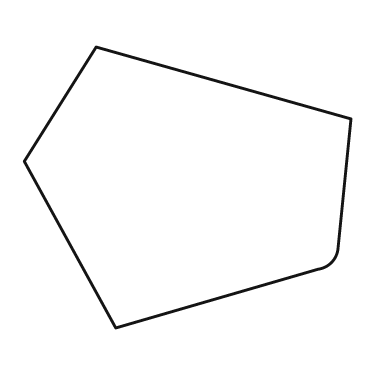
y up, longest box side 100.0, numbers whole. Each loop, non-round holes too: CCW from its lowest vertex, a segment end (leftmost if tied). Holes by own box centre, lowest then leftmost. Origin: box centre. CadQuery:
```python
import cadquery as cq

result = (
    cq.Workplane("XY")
    .moveTo(-22.0, -43.0)
    .lineTo(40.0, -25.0)
    .threePointArc((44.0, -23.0), (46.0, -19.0))
    .lineTo(50.0, 21.0)
    .lineTo(-28.0, 43.0)
    .lineTo(-50.0, 8.0)
    .close()
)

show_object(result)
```